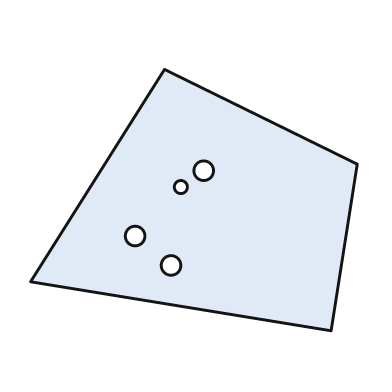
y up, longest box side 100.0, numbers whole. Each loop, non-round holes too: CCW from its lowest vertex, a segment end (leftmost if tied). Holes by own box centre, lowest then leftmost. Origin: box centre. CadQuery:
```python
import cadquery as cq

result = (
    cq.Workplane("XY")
    .moveTo(42.0, -40.0)
    .lineTo(50.0, 11.0)
    .lineTo(-9.0, 40.0)
    .lineTo(-50.0, -25.0)
    .close()
    .moveTo(-7.0, -20.0)
    .circle(3.0)
    .moveTo(-18.0, -11.0)
    .circle(3.0)
    .moveTo(-4.0, 4.0)
    .circle(2.0)
    .moveTo(3.0, 9.0)
    .circle(3.0)
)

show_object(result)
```